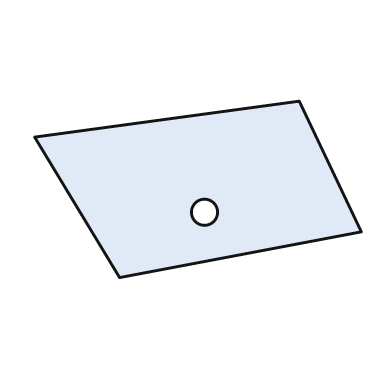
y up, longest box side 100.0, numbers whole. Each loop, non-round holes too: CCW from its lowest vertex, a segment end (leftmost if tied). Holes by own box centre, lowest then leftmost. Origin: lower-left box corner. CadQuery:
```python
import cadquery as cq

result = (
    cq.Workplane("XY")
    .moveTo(26.0, 0.0)
    .lineTo(100.0, 14.0)
    .lineTo(81.0, 54.0)
    .lineTo(0.0, 43.0)
    .close()
    .moveTo(52.0, 20.0)
    .circle(4.0)
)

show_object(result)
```